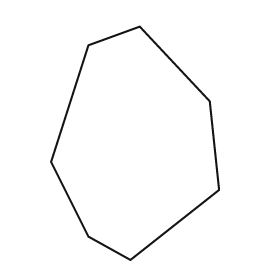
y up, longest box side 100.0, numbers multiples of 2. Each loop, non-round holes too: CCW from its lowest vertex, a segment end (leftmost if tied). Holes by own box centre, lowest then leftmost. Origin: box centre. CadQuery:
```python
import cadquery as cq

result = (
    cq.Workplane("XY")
    .moveTo(-2.0, -50.0)
    .lineTo(36.0, -20.0)
    .lineTo(32.0, 18.0)
    .lineTo(2.0, 50.0)
    .lineTo(-20.0, 42.0)
    .lineTo(-36.0, -8.0)
    .lineTo(-20.0, -40.0)
    .close()
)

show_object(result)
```